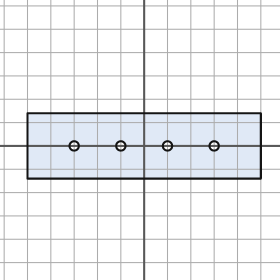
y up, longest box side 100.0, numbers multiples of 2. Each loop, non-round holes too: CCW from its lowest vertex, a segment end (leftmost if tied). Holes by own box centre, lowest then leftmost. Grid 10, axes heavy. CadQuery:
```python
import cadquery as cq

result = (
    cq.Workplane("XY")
    .moveTo(-50.0, -14.0)
    .lineTo(50.0, -14.0)
    .lineTo(50.0, 14.0)
    .lineTo(-50.0, 14.0)
    .close()
    .moveTo(-30.0, 0.0)
    .circle(2.0)
    .moveTo(-10.0, 0.0)
    .circle(2.0)
    .moveTo(10.0, 0.0)
    .circle(2.0)
    .moveTo(30.0, 0.0)
    .circle(2.0)
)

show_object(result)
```